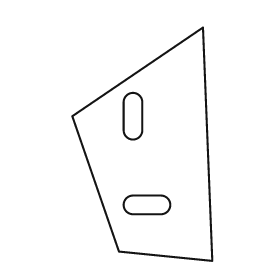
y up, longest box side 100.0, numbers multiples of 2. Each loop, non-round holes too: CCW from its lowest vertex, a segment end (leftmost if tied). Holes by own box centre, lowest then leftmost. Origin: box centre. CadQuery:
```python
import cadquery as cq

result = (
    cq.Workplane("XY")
    .moveTo(30.0, -50.0)
    .lineTo(26.0, 50.0)
    .lineTo(-30.0, 12.0)
    .lineTo(-10.0, -46.0)
    .close()
    .moveTo(-4.0, -30.0)
    .lineTo(8.0, -30.0)
    .threePointArc((12.0, -26.0), (8.0, -22.0))
    .lineTo(-4.0, -22.0)
    .threePointArc((-8.0, -26.0), (-4.0, -30.0))
    .close()
    .moveTo(-8.0, 6.0)
    .threePointArc((-4.0, 2.0), (0.0, 6.0))
    .lineTo(0.0, 18.0)
    .threePointArc((-4.0, 22.0), (-8.0, 18.0))
    .close()
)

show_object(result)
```